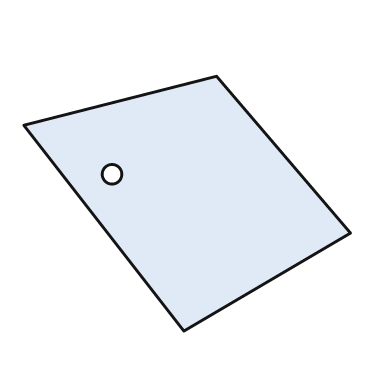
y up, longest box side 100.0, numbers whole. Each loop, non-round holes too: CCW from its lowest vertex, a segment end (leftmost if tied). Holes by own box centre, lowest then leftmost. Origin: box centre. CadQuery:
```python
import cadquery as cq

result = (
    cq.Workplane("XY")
    .moveTo(-1.0, -39.0)
    .lineTo(50.0, -9.0)
    .lineTo(9.0, 39.0)
    .lineTo(-50.0, 24.0)
    .close()
    .moveTo(-23.0, 9.0)
    .circle(3.0)
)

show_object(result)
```